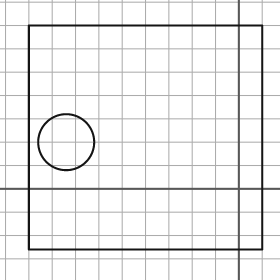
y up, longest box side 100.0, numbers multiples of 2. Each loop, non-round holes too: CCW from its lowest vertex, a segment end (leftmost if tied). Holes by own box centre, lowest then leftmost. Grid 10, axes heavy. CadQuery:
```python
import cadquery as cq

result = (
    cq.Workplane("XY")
    .moveTo(-90.0, -26.0)
    .lineTo(10.0, -26.0)
    .lineTo(10.0, 70.0)
    .lineTo(-90.0, 70.0)
    .close()
    .moveTo(-74.0, 20.0)
    .circle(12.0)
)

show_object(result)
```